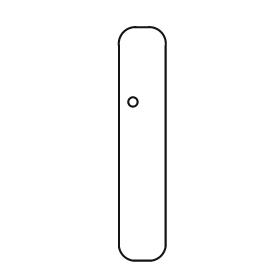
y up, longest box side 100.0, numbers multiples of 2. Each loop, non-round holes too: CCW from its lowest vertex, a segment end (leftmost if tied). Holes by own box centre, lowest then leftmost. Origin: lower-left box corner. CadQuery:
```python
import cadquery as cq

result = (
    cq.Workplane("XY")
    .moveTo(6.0, 0.0)
    .lineTo(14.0, 0.0)
    .threePointArc((18.0, 2.0), (20.0, 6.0))
    .lineTo(20.0, 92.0)
    .threePointArc((18.0, 98.0), (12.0, 100.0))
    .lineTo(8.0, 100.0)
    .threePointArc((2.0, 98.0), (0.0, 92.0))
    .lineTo(0.0, 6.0)
    .threePointArc((2.0, 2.0), (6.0, 0.0))
    .close()
    .moveTo(6.0, 68.0)
    .circle(2.0)
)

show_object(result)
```